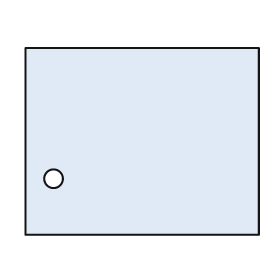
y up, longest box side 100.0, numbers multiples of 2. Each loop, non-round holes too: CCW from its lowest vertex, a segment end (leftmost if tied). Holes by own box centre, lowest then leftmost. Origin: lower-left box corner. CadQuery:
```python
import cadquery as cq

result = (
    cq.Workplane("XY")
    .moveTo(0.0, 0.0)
    .lineTo(100.0, 0.0)
    .lineTo(100.0, 80.0)
    .lineTo(0.0, 80.0)
    .close()
    .moveTo(12.0, 24.0)
    .circle(4.0)
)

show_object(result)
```